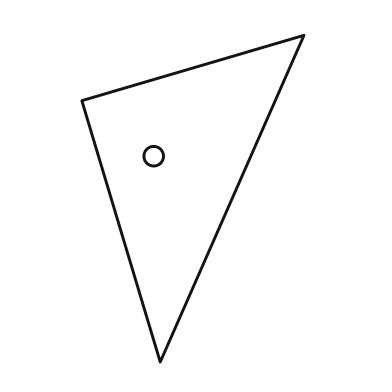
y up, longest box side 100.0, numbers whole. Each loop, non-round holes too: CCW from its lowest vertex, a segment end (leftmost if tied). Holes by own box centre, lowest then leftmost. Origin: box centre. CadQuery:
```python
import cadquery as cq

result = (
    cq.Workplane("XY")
    .moveTo(-10.0, -50.0)
    .lineTo(34.0, 50.0)
    .lineTo(-34.0, 30.0)
    .close()
    .moveTo(-12.0, 13.0)
    .circle(3.0)
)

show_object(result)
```